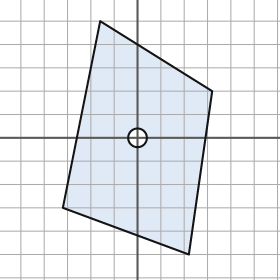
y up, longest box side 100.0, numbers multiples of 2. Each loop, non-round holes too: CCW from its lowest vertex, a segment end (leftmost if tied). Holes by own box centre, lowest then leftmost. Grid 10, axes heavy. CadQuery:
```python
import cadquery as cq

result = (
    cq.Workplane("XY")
    .moveTo(22.0, -50.0)
    .lineTo(32.0, 20.0)
    .lineTo(-16.0, 50.0)
    .lineTo(-32.0, -30.0)
    .close()
    .moveTo(0.0, 0.0)
    .circle(4.0)
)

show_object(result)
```